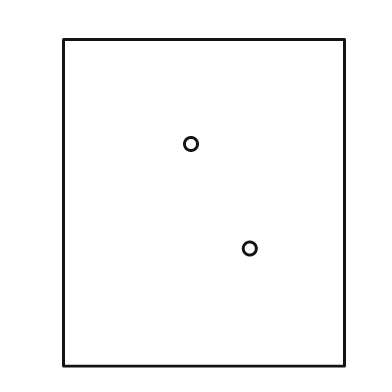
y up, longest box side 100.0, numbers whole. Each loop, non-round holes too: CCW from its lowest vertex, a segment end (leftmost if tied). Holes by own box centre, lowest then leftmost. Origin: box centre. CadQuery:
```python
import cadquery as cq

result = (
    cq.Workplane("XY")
    .moveTo(-43.0, -50.0)
    .lineTo(43.0, -50.0)
    .lineTo(43.0, 50.0)
    .lineTo(-43.0, 50.0)
    .close()
    .moveTo(14.0, -14.0)
    .circle(2.0)
    .moveTo(-4.0, 18.0)
    .circle(2.0)
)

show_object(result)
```